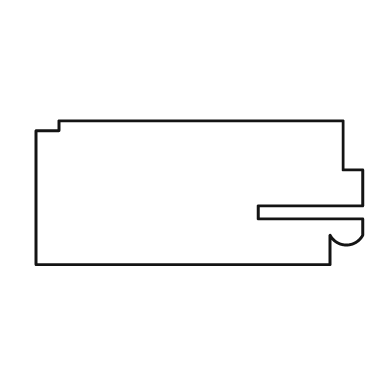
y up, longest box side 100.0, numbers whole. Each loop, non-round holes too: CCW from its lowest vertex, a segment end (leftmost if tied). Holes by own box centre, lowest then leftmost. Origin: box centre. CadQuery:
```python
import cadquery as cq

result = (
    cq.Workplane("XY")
    .moveTo(-50.0, -22.0)
    .lineTo(40.0, -22.0)
    .lineTo(40.0, -13.0)
    .threePointArc((45.0, -16.0), (50.0, -13.0))
    .lineTo(50.0, -8.0)
    .lineTo(18.0, -8.0)
    .lineTo(18.0, -4.0)
    .lineTo(50.0, -4.0)
    .lineTo(50.0, 7.0)
    .lineTo(44.0, 7.0)
    .lineTo(44.0, 22.0)
    .lineTo(-43.0, 22.0)
    .lineTo(-43.0, 19.0)
    .lineTo(-50.0, 19.0)
    .close()
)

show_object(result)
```